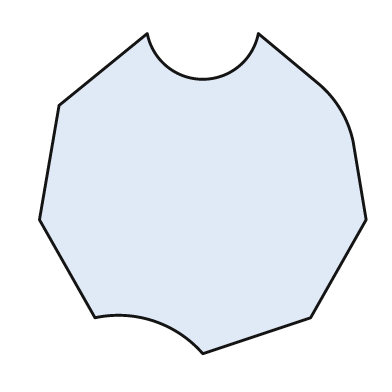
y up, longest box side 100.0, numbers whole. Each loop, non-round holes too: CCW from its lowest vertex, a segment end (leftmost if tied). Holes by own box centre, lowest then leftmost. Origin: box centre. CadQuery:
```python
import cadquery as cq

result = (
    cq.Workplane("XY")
    .moveTo(0.0, -49.0)
    .lineTo(33.0, -38.0)
    .lineTo(50.0, -8.0)
    .lineTo(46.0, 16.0)
    .threePointArc((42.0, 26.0), (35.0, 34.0))
    .lineTo(17.0, 49.0)
    .threePointArc((0.0, 35.0), (-17.0, 49.0))
    .lineTo(-44.0, 27.0)
    .lineTo(-50.0, -8.0)
    .lineTo(-33.0, -38.0)
    .threePointArc((-15.0, -39.0), (0.0, -49.0))
    .close()
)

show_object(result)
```